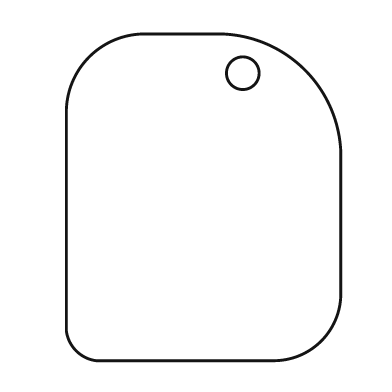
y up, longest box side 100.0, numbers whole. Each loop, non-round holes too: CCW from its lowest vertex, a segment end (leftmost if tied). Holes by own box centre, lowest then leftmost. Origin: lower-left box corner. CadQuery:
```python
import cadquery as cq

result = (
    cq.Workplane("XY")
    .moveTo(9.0, 0.0)
    .lineTo(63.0, 0.0)
    .threePointArc((78.0, 6.0), (84.0, 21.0))
    .lineTo(84.0, 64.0)
    .threePointArc((73.0, 89.0), (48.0, 100.0))
    .lineTo(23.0, 100.0)
    .threePointArc((7.0, 93.0), (0.0, 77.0))
    .lineTo(0.0, 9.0)
    .threePointArc((3.0, 3.0), (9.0, 0.0))
    .close()
    .moveTo(54.0, 88.0)
    .circle(5.0)
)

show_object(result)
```